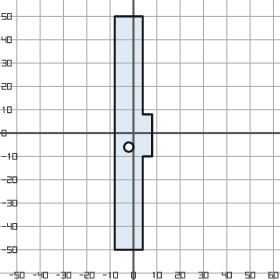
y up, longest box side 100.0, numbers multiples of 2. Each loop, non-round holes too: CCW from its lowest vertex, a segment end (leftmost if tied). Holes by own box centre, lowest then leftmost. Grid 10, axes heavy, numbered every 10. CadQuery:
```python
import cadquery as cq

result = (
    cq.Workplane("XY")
    .moveTo(-8.0, -50.0)
    .lineTo(4.0, -50.0)
    .lineTo(4.0, -10.0)
    .lineTo(8.0, -10.0)
    .lineTo(8.0, 8.0)
    .lineTo(4.0, 8.0)
    .lineTo(4.0, 50.0)
    .lineTo(-8.0, 50.0)
    .close()
    .moveTo(-2.0, -6.0)
    .circle(2.0)
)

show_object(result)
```